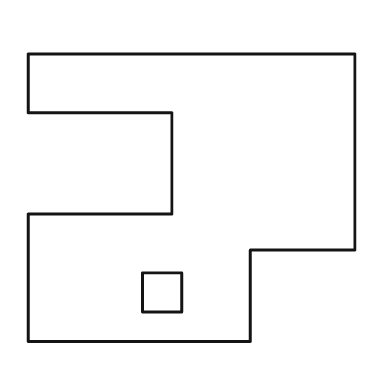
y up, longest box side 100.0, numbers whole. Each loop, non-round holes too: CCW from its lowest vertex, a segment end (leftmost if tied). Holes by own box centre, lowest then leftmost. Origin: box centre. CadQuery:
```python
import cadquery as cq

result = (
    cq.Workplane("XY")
    .moveTo(-50.0, -44.0)
    .lineTo(18.0, -44.0)
    .lineTo(18.0, -16.0)
    .lineTo(50.0, -16.0)
    .lineTo(50.0, 44.0)
    .lineTo(-50.0, 44.0)
    .lineTo(-50.0, 26.0)
    .lineTo(-6.0, 26.0)
    .lineTo(-6.0, -5.0)
    .lineTo(-50.0, -5.0)
    .close()
    .moveTo(-15.0, -35.0)
    .lineTo(-3.0, -35.0)
    .lineTo(-3.0, -23.0)
    .lineTo(-15.0, -23.0)
    .close()
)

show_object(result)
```